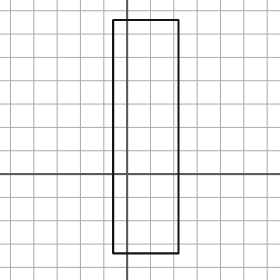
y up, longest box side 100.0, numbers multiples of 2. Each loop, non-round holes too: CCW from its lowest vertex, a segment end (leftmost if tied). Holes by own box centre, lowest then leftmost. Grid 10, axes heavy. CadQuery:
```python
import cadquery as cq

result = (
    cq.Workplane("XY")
    .moveTo(-6.0, -34.0)
    .lineTo(22.0, -34.0)
    .lineTo(22.0, 66.0)
    .lineTo(-6.0, 66.0)
    .close()
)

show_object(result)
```